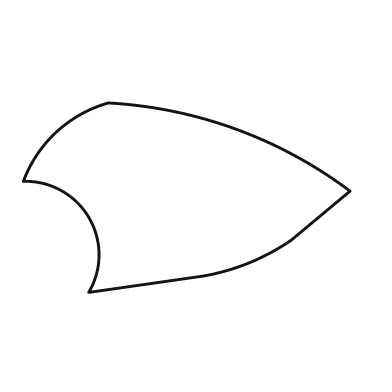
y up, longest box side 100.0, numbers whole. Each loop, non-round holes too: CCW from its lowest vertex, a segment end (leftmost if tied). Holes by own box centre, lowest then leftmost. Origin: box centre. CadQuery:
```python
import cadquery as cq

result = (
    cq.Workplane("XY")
    .moveTo(-30.0, -29.0)
    .lineTo(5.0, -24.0)
    .threePointArc((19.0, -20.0), (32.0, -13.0))
    .lineTo(50.0, 2.0)
    .threePointArc((15.0, 21.0), (-24.0, 29.0))
    .threePointArc((-40.0, 20.0), (-50.0, 5.0))
    .threePointArc((-30.0, -6.0), (-30.0, -29.0))
    .close()
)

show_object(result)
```